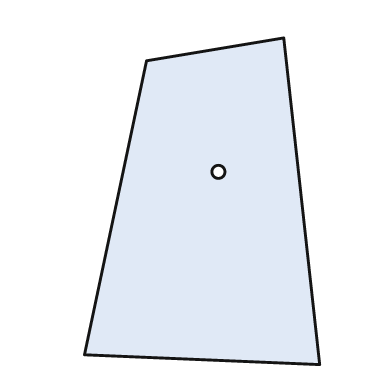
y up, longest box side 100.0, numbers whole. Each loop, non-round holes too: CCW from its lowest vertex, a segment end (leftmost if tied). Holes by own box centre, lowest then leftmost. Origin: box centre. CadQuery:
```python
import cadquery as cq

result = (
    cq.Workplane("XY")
    .moveTo(36.0, -50.0)
    .lineTo(25.0, 50.0)
    .lineTo(-17.0, 43.0)
    .lineTo(-36.0, -47.0)
    .close()
    .moveTo(5.0, 9.0)
    .circle(2.0)
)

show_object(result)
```